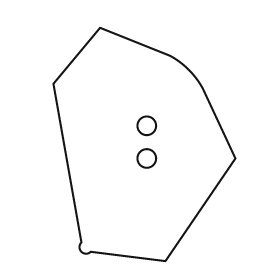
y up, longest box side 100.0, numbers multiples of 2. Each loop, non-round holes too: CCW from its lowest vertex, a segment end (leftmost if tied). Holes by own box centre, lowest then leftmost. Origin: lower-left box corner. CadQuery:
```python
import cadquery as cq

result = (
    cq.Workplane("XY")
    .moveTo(48.0, 0.0)
    .lineTo(78.0, 44.0)
    .lineTo(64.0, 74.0)
    .threePointArc((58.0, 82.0), (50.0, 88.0))
    .lineTo(20.0, 100.0)
    .lineTo(0.0, 76.0)
    .lineTo(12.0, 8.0)
    .threePointArc((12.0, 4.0), (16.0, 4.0))
    .close()
    .moveTo(40.0, 44.0)
    .circle(4.0)
    .moveTo(40.0, 58.0)
    .circle(4.0)
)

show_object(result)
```